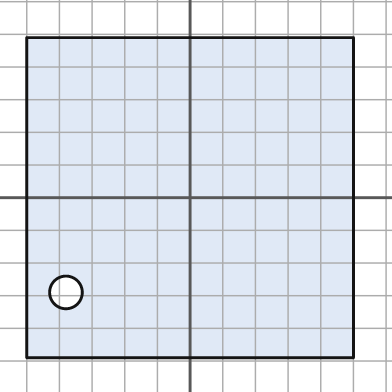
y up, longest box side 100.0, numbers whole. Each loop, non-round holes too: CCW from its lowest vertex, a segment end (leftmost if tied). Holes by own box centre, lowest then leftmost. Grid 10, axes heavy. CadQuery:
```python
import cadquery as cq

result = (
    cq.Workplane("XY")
    .moveTo(-50.0, -49.0)
    .lineTo(50.0, -49.0)
    .lineTo(50.0, 49.0)
    .lineTo(-50.0, 49.0)
    .close()
    .moveTo(-38.0, -29.0)
    .circle(5.0)
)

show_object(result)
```